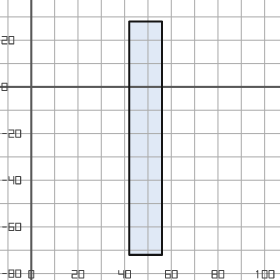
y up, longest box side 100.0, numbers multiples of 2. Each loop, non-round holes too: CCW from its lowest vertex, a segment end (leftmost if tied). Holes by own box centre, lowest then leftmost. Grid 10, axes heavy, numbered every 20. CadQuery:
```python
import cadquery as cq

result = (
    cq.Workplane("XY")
    .moveTo(42.0, -72.0)
    .lineTo(56.0, -72.0)
    .lineTo(56.0, 28.0)
    .lineTo(42.0, 28.0)
    .close()
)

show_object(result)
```